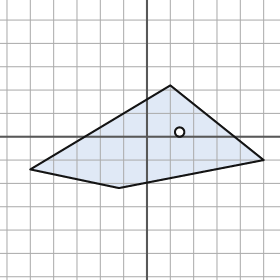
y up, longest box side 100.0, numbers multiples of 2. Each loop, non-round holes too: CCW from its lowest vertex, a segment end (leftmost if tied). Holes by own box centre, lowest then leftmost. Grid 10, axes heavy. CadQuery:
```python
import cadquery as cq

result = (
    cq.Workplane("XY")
    .moveTo(-12.0, -22.0)
    .lineTo(50.0, -10.0)
    .lineTo(10.0, 22.0)
    .lineTo(-50.0, -14.0)
    .close()
    .moveTo(14.0, 2.0)
    .circle(2.0)
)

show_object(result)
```